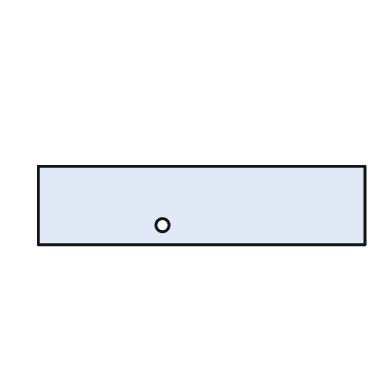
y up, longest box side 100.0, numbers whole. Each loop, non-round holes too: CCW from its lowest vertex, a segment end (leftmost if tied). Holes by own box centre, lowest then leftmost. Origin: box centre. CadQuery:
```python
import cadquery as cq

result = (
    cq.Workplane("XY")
    .moveTo(-50.0, -12.0)
    .lineTo(50.0, -12.0)
    .lineTo(50.0, 12.0)
    .lineTo(-50.0, 12.0)
    .close()
    .moveTo(-12.0, -6.0)
    .circle(2.0)
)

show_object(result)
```